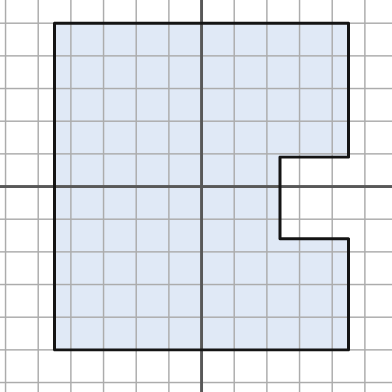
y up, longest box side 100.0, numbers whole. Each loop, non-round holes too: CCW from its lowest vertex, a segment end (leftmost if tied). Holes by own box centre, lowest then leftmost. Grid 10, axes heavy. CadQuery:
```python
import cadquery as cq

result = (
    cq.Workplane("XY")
    .moveTo(-45.0, -50.0)
    .lineTo(45.0, -50.0)
    .lineTo(45.0, -16.0)
    .lineTo(24.0, -16.0)
    .lineTo(24.0, 9.0)
    .lineTo(45.0, 9.0)
    .lineTo(45.0, 50.0)
    .lineTo(-45.0, 50.0)
    .close()
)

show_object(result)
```